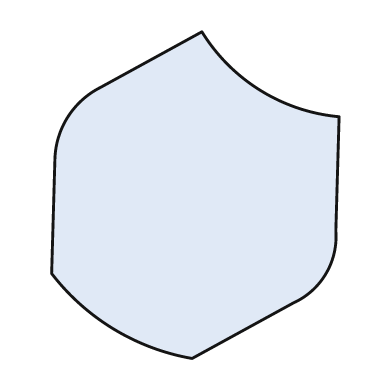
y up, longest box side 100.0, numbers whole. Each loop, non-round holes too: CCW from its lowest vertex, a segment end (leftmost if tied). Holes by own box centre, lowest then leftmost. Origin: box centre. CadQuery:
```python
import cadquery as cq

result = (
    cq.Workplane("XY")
    .moveTo(-1.0, -50.0)
    .lineTo(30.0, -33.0)
    .threePointArc((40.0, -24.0), (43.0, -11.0))
    .lineTo(44.0, 24.0)
    .threePointArc((20.0, 32.0), (2.0, 50.0))
    .lineTo(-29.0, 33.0)
    .threePointArc((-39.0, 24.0), (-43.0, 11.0))
    .lineTo(-44.0, -24.0)
    .threePointArc((-25.0, -41.0), (-1.0, -50.0))
    .close()
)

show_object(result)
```